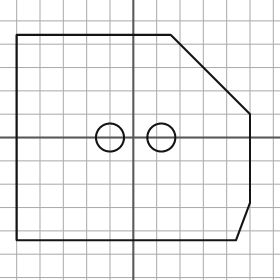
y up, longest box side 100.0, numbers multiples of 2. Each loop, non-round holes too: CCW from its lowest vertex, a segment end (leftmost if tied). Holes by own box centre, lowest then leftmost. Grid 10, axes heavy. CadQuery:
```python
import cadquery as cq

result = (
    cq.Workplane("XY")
    .moveTo(-50.0, -44.0)
    .lineTo(44.0, -44.0)
    .lineTo(50.0, -28.0)
    .lineTo(50.0, 10.0)
    .lineTo(16.0, 44.0)
    .lineTo(-50.0, 44.0)
    .close()
    .moveTo(-10.0, 0.0)
    .circle(6.0)
    .moveTo(12.0, 0.0)
    .circle(6.0)
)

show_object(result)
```